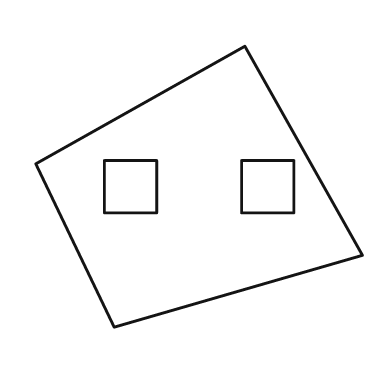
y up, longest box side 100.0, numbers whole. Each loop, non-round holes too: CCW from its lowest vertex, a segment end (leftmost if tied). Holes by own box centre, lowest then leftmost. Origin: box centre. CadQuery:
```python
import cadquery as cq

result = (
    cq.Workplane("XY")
    .moveTo(-26.0, -43.0)
    .lineTo(50.0, -21.0)
    .lineTo(14.0, 43.0)
    .lineTo(-50.0, 7.0)
    .close()
    .moveTo(-29.0, -8.0)
    .lineTo(-13.0, -8.0)
    .lineTo(-13.0, 8.0)
    .lineTo(-29.0, 8.0)
    .close()
    .moveTo(13.0, -8.0)
    .lineTo(29.0, -8.0)
    .lineTo(29.0, 8.0)
    .lineTo(13.0, 8.0)
    .close()
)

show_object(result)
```